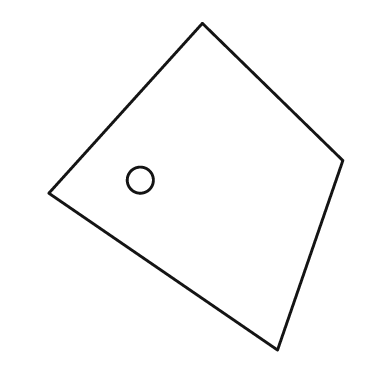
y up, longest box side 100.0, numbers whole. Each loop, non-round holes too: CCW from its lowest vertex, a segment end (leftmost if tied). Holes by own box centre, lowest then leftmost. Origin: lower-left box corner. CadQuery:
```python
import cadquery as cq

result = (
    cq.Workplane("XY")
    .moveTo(70.0, 0.0)
    .lineTo(90.0, 58.0)
    .lineTo(47.0, 100.0)
    .lineTo(0.0, 48.0)
    .close()
    .moveTo(28.0, 52.0)
    .circle(4.0)
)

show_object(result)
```